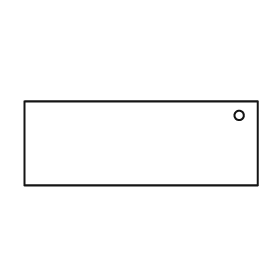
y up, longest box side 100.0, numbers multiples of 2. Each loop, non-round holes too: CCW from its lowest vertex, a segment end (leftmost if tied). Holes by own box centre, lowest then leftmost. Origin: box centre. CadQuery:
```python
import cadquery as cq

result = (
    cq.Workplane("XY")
    .moveTo(-50.0, -18.0)
    .lineTo(50.0, -18.0)
    .lineTo(50.0, 18.0)
    .lineTo(-50.0, 18.0)
    .close()
    .moveTo(42.0, 12.0)
    .circle(2.0)
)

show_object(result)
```